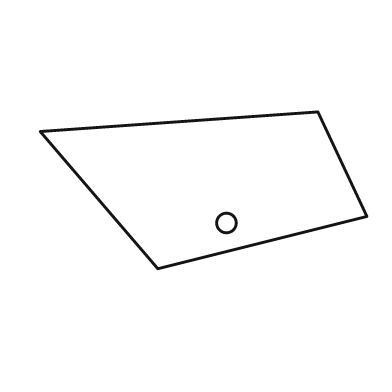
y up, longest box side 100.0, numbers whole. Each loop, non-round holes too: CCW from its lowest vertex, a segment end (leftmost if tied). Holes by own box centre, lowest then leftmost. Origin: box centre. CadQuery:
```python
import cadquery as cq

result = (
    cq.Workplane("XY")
    .moveTo(-14.0, -24.0)
    .lineTo(50.0, -8.0)
    .lineTo(35.0, 24.0)
    .lineTo(-50.0, 18.0)
    .close()
    .moveTo(7.0, -10.0)
    .circle(3.0)
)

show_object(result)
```